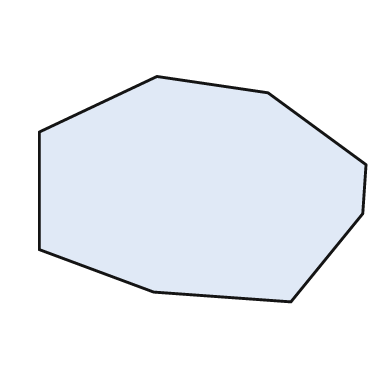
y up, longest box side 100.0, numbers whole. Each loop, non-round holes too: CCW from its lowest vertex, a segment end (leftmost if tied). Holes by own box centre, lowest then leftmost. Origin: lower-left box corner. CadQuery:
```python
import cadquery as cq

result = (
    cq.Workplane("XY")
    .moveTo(77.0, 0.0)
    .lineTo(99.0, 27.0)
    .lineTo(100.0, 42.0)
    .lineTo(70.0, 64.0)
    .lineTo(36.0, 69.0)
    .lineTo(0.0, 52.0)
    .lineTo(0.0, 16.0)
    .lineTo(35.0, 3.0)
    .close()
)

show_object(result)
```